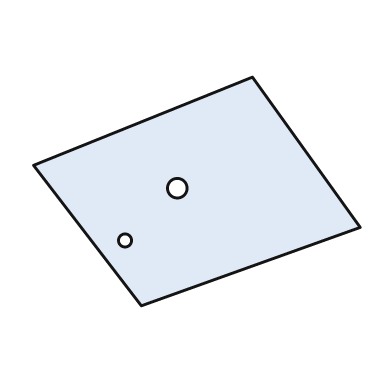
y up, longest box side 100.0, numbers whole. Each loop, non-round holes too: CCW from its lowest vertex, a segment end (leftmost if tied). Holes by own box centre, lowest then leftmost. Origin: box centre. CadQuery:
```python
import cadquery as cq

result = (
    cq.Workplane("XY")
    .moveTo(-17.0, -35.0)
    .lineTo(50.0, -11.0)
    .lineTo(17.0, 35.0)
    .lineTo(-50.0, 8.0)
    .close()
    .moveTo(-22.0, -15.0)
    .circle(2.0)
    .moveTo(-6.0, 1.0)
    .circle(3.0)
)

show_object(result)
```